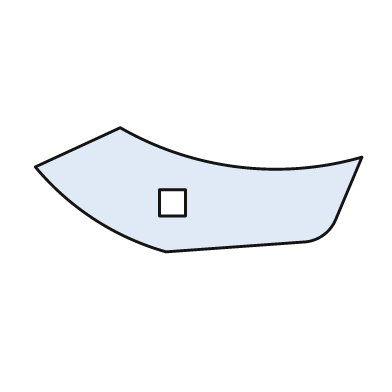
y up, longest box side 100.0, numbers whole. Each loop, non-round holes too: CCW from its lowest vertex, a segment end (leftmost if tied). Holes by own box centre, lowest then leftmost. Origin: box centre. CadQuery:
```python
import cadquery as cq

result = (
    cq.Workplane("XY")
    .moveTo(-10.0, -19.0)
    .lineTo(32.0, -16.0)
    .threePointArc((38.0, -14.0), (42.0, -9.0))
    .lineTo(50.0, 10.0)
    .threePointArc((12.0, 7.0), (-24.0, 19.0))
    .lineTo(-50.0, 7.0)
    .threePointArc((-32.0, -9.0), (-10.0, -19.0))
    .close()
    .moveTo(-12.0, -8.0)
    .lineTo(-4.0, -8.0)
    .lineTo(-4.0, 0.0)
    .lineTo(-12.0, 0.0)
    .close()
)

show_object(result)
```